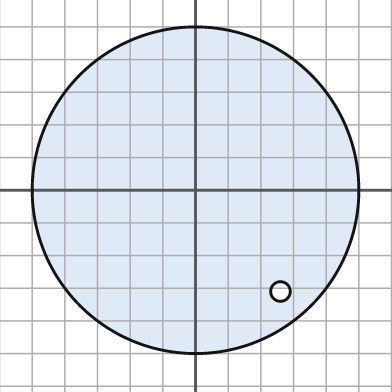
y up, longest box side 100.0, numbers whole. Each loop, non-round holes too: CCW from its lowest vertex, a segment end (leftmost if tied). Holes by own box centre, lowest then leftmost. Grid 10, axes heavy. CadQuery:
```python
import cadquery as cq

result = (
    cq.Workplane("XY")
    .moveTo(0.0, 0.0)
    .circle(50.0)
    .moveTo(26.0, -31.0)
    .circle(3.0)
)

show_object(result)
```